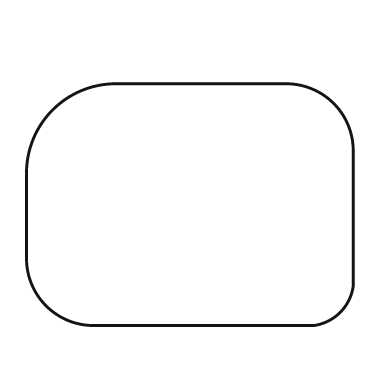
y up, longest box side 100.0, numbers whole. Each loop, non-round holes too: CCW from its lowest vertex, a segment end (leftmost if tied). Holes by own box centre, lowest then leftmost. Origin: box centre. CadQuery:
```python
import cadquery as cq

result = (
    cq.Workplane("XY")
    .moveTo(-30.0, -37.0)
    .lineTo(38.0, -37.0)
    .threePointArc((46.0, -33.0), (50.0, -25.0))
    .lineTo(50.0, 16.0)
    .threePointArc((44.0, 31.0), (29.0, 37.0))
    .lineTo(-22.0, 37.0)
    .threePointArc((-42.0, 29.0), (-50.0, 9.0))
    .lineTo(-50.0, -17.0)
    .threePointArc((-44.0, -31.0), (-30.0, -37.0))
    .close()
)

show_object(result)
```